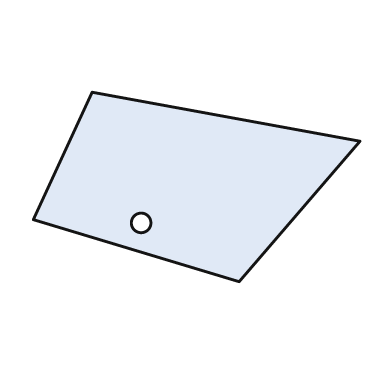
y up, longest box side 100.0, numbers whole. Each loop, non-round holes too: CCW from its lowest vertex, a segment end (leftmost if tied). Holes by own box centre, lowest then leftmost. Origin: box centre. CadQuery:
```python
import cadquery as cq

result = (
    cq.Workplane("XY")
    .moveTo(13.0, -29.0)
    .lineTo(50.0, 14.0)
    .lineTo(-32.0, 29.0)
    .lineTo(-50.0, -10.0)
    .close()
    .moveTo(-17.0, -11.0)
    .circle(3.0)
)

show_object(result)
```